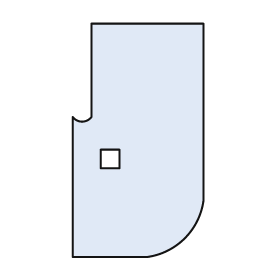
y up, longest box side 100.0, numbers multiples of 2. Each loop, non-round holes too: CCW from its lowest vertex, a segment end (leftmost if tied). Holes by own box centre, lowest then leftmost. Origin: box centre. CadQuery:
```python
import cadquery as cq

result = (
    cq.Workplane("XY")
    .moveTo(-28.0, -50.0)
    .lineTo(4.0, -50.0)
    .threePointArc((20.0, -42.0), (28.0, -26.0))
    .lineTo(28.0, 50.0)
    .lineTo(-20.0, 50.0)
    .lineTo(-20.0, 10.0)
    .threePointArc((-24.0, 8.0), (-28.0, 10.0))
    .close()
    .moveTo(-16.0, -12.0)
    .lineTo(-8.0, -12.0)
    .lineTo(-8.0, -4.0)
    .lineTo(-16.0, -4.0)
    .close()
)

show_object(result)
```